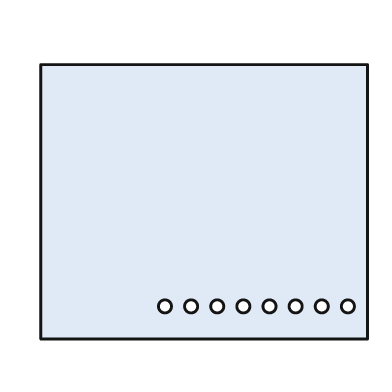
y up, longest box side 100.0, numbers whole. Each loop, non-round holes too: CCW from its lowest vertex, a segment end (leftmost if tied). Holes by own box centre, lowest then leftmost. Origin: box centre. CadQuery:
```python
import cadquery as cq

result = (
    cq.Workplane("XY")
    .moveTo(-50.0, -42.0)
    .lineTo(50.0, -42.0)
    .lineTo(50.0, 42.0)
    .lineTo(-50.0, 42.0)
    .close()
    .moveTo(-12.0, -32.0)
    .circle(2.0)
    .moveTo(-4.0, -32.0)
    .circle(2.0)
    .moveTo(4.0, -32.0)
    .circle(2.0)
    .moveTo(12.0, -32.0)
    .circle(2.0)
    .moveTo(20.0, -32.0)
    .circle(2.0)
    .moveTo(28.0, -32.0)
    .circle(2.0)
    .moveTo(36.0, -32.0)
    .circle(2.0)
    .moveTo(44.0, -32.0)
    .circle(2.0)
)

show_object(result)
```